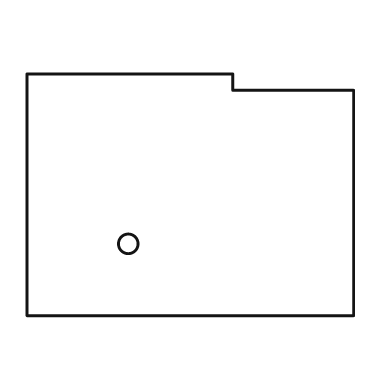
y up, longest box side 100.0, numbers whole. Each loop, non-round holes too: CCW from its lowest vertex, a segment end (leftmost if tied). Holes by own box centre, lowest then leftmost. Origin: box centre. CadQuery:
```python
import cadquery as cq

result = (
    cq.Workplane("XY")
    .moveTo(-50.0, -37.0)
    .lineTo(50.0, -37.0)
    .lineTo(50.0, 32.0)
    .lineTo(13.0, 32.0)
    .lineTo(13.0, 37.0)
    .lineTo(-50.0, 37.0)
    .close()
    .moveTo(-19.0, -15.0)
    .circle(3.0)
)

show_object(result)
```